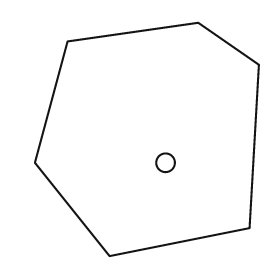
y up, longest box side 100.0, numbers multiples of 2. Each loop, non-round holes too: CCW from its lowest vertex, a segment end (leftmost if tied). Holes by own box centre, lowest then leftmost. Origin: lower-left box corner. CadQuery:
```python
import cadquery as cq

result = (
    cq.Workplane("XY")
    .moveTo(32.0, 0.0)
    .lineTo(92.0, 12.0)
    .lineTo(96.0, 82.0)
    .lineTo(70.0, 100.0)
    .lineTo(14.0, 92.0)
    .lineTo(0.0, 40.0)
    .close()
    .moveTo(56.0, 40.0)
    .circle(4.0)
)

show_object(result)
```